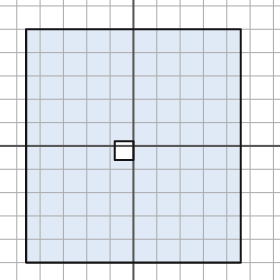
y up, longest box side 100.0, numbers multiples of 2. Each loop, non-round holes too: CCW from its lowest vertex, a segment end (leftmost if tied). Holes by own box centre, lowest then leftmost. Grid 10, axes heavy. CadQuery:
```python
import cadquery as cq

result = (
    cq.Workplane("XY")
    .moveTo(-46.0, -50.0)
    .lineTo(46.0, -50.0)
    .lineTo(46.0, 50.0)
    .lineTo(-46.0, 50.0)
    .close()
    .moveTo(-8.0, -6.0)
    .lineTo(0.0, -6.0)
    .lineTo(0.0, 2.0)
    .lineTo(-8.0, 2.0)
    .close()
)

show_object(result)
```